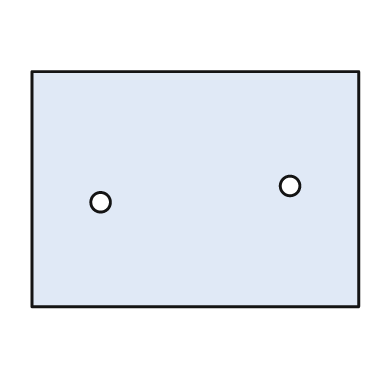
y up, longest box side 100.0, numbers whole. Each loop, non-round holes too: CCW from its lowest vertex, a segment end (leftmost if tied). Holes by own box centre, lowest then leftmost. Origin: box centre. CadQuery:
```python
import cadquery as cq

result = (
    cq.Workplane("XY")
    .moveTo(-50.0, -36.0)
    .lineTo(50.0, -36.0)
    .lineTo(50.0, 36.0)
    .lineTo(-50.0, 36.0)
    .close()
    .moveTo(-29.0, -4.0)
    .circle(3.0)
    .moveTo(29.0, 1.0)
    .circle(3.0)
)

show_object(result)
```